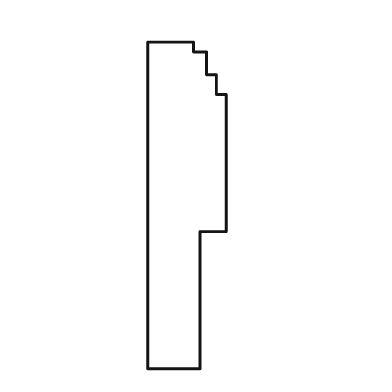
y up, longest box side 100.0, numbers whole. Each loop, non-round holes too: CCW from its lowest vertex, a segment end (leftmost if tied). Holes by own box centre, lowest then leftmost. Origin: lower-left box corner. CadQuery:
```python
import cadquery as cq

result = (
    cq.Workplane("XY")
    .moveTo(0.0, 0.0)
    .lineTo(16.0, 0.0)
    .lineTo(16.0, 42.0)
    .lineTo(24.0, 42.0)
    .lineTo(24.0, 84.0)
    .lineTo(21.0, 84.0)
    .lineTo(21.0, 90.0)
    .lineTo(18.0, 90.0)
    .lineTo(18.0, 97.0)
    .lineTo(14.0, 97.0)
    .lineTo(14.0, 100.0)
    .lineTo(0.0, 100.0)
    .close()
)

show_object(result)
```